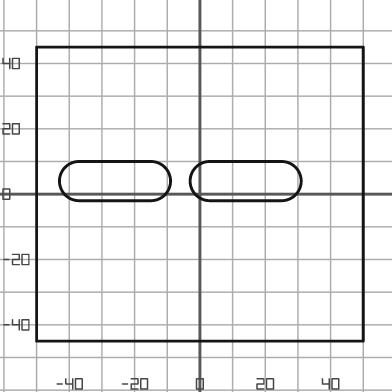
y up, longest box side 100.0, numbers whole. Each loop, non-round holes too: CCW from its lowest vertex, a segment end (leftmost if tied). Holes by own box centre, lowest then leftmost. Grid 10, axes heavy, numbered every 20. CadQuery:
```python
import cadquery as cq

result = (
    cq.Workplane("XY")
    .moveTo(-50.0, -45.0)
    .lineTo(50.0, -45.0)
    .lineTo(50.0, 45.0)
    .lineTo(-50.0, 45.0)
    .close()
    .moveTo(-37.0, -2.0)
    .lineTo(-15.0, -2.0)
    .threePointArc((-9.0, 4.0), (-15.0, 10.0))
    .lineTo(-37.0, 10.0)
    .threePointArc((-43.0, 4.0), (-37.0, -2.0))
    .close()
    .moveTo(3.0, -2.0)
    .lineTo(25.0, -2.0)
    .threePointArc((31.0, 4.0), (25.0, 10.0))
    .lineTo(3.0, 10.0)
    .threePointArc((-3.0, 4.0), (3.0, -2.0))
    .close()
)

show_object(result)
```